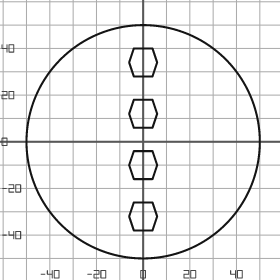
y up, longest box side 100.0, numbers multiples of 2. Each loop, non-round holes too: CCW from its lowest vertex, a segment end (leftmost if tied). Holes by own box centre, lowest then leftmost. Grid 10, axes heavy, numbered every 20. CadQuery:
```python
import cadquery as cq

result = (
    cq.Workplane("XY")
    .moveTo(0.0, 0.0)
    .circle(50.0)
    .moveTo(-4.0, -38.0)
    .lineTo(4.0, -38.0)
    .lineTo(6.0, -32.0)
    .lineTo(4.0, -26.0)
    .lineTo(-4.0, -26.0)
    .lineTo(-6.0, -32.0)
    .close()
    .moveTo(-4.0, -16.0)
    .lineTo(4.0, -16.0)
    .lineTo(6.0, -10.0)
    .lineTo(4.0, -4.0)
    .lineTo(-4.0, -4.0)
    .lineTo(-6.0, -10.0)
    .close()
    .moveTo(-4.0, 6.0)
    .lineTo(4.0, 6.0)
    .lineTo(6.0, 12.0)
    .lineTo(4.0, 18.0)
    .lineTo(-4.0, 18.0)
    .lineTo(-6.0, 12.0)
    .close()
    .moveTo(-4.0, 28.0)
    .lineTo(4.0, 28.0)
    .lineTo(6.0, 34.0)
    .lineTo(4.0, 40.0)
    .lineTo(-4.0, 40.0)
    .lineTo(-6.0, 34.0)
    .close()
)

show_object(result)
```